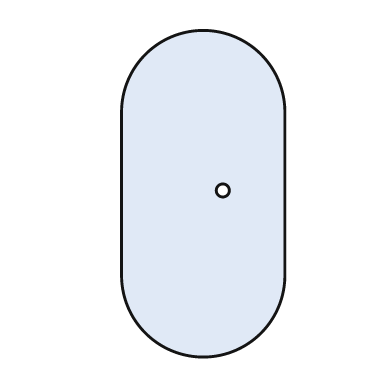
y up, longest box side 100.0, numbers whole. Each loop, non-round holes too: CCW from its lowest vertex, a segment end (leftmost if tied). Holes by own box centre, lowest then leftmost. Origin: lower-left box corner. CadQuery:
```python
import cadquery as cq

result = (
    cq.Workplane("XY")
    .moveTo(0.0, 25.0)
    .threePointArc((25.0, 0.0), (50.0, 25.0))
    .lineTo(50.0, 75.0)
    .threePointArc((25.0, 100.0), (0.0, 75.0))
    .close()
    .moveTo(31.0, 51.0)
    .circle(2.0)
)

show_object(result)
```